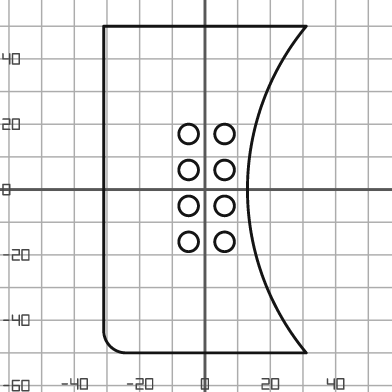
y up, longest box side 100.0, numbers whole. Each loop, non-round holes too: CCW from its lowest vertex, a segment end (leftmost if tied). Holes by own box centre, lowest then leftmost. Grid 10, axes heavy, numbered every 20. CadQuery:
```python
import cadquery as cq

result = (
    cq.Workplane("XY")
    .moveTo(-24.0, -50.0)
    .lineTo(31.0, -50.0)
    .threePointArc((13.0, 0.0), (31.0, 50.0))
    .lineTo(-31.0, 50.0)
    .lineTo(-31.0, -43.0)
    .threePointArc((-29.0, -48.0), (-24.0, -50.0))
    .close()
    .moveTo(-5.0, -16.0)
    .circle(3.0)
    .moveTo(6.0, -16.0)
    .circle(3.0)
    .moveTo(-5.0, -5.0)
    .circle(3.0)
    .moveTo(6.0, -5.0)
    .circle(3.0)
    .moveTo(-5.0, 6.0)
    .circle(3.0)
    .moveTo(6.0, 6.0)
    .circle(3.0)
    .moveTo(-5.0, 17.0)
    .circle(3.0)
    .moveTo(6.0, 17.0)
    .circle(3.0)
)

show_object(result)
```